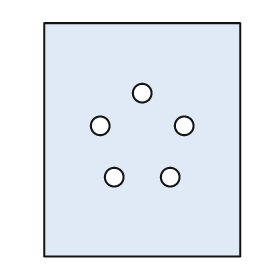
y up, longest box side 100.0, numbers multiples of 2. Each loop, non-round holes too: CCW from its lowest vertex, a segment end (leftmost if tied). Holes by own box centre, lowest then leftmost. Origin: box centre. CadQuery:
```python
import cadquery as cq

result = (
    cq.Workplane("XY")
    .moveTo(-42.0, -50.0)
    .lineTo(42.0, -50.0)
    .lineTo(42.0, 50.0)
    .lineTo(-42.0, 50.0)
    .close()
    .moveTo(-12.0, -16.0)
    .circle(4.0)
    .moveTo(12.0, -16.0)
    .circle(4.0)
    .moveTo(-18.0, 6.0)
    .circle(4.0)
    .moveTo(18.0, 6.0)
    .circle(4.0)
    .moveTo(0.0, 20.0)
    .circle(4.0)
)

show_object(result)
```